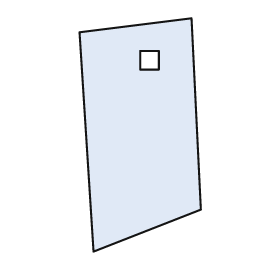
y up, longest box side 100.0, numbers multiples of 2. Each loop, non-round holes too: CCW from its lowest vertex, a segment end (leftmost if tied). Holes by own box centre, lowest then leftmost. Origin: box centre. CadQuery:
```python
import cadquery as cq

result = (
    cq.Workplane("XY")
    .moveTo(-20.0, -50.0)
    .lineTo(26.0, -32.0)
    .lineTo(22.0, 50.0)
    .lineTo(-26.0, 44.0)
    .close()
    .moveTo(0.0, 28.0)
    .lineTo(8.0, 28.0)
    .lineTo(8.0, 36.0)
    .lineTo(0.0, 36.0)
    .close()
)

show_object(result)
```